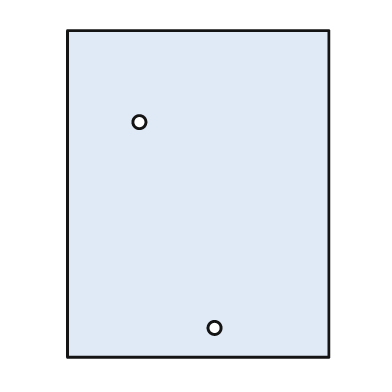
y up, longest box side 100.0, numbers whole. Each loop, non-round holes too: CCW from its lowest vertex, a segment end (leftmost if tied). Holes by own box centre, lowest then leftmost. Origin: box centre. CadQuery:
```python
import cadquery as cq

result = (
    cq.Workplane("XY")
    .moveTo(-40.0, -50.0)
    .lineTo(40.0, -50.0)
    .lineTo(40.0, 50.0)
    .lineTo(-40.0, 50.0)
    .close()
    .moveTo(5.0, -41.0)
    .circle(2.0)
    .moveTo(-18.0, 22.0)
    .circle(2.0)
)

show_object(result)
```